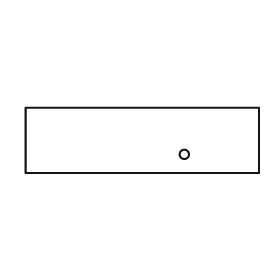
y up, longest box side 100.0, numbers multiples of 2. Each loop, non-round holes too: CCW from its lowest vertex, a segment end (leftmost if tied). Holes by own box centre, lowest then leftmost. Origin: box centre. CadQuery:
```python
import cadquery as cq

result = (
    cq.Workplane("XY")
    .moveTo(-50.0, -14.0)
    .lineTo(50.0, -14.0)
    .lineTo(50.0, 14.0)
    .lineTo(-50.0, 14.0)
    .close()
    .moveTo(18.0, -6.0)
    .circle(2.0)
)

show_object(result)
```